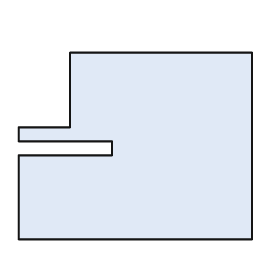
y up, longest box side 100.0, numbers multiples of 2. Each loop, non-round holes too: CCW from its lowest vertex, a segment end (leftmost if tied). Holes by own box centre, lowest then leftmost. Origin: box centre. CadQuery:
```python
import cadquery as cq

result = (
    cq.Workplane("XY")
    .moveTo(-50.0, -40.0)
    .lineTo(50.0, -40.0)
    .lineTo(50.0, 40.0)
    .lineTo(-28.0, 40.0)
    .lineTo(-28.0, 8.0)
    .lineTo(-50.0, 8.0)
    .lineTo(-50.0, 2.0)
    .lineTo(-10.0, 2.0)
    .lineTo(-10.0, -4.0)
    .lineTo(-50.0, -4.0)
    .close()
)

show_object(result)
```